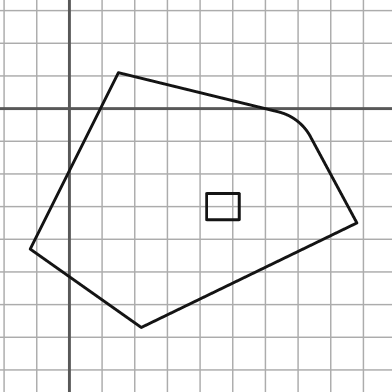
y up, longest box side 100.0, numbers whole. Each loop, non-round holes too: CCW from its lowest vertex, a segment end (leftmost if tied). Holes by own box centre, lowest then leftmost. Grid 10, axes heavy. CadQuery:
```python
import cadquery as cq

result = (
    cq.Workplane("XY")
    .moveTo(22.0, -67.0)
    .lineTo(88.0, -35.0)
    .lineTo(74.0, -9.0)
    .threePointArc((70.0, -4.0), (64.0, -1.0))
    .lineTo(15.0, 11.0)
    .lineTo(-12.0, -43.0)
    .close()
    .moveTo(42.0, -34.0)
    .lineTo(52.0, -34.0)
    .lineTo(52.0, -26.0)
    .lineTo(42.0, -26.0)
    .close()
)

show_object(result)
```